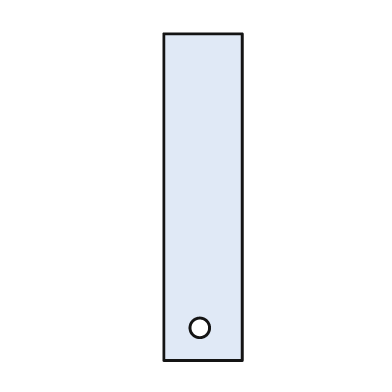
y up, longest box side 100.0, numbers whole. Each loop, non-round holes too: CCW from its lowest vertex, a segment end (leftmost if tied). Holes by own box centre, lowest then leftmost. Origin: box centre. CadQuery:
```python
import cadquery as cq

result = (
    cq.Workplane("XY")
    .moveTo(-12.0, -50.0)
    .lineTo(12.0, -50.0)
    .lineTo(12.0, 50.0)
    .lineTo(-12.0, 50.0)
    .close()
    .moveTo(-1.0, -40.0)
    .circle(3.0)
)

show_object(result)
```